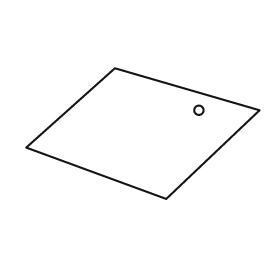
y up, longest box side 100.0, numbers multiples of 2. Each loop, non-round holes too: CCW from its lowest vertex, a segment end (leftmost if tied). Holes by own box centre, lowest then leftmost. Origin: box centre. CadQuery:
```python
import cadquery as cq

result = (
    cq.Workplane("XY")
    .moveTo(10.0, -28.0)
    .lineTo(50.0, 10.0)
    .lineTo(-12.0, 28.0)
    .lineTo(-50.0, -6.0)
    .close()
    .moveTo(24.0, 10.0)
    .circle(2.0)
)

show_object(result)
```